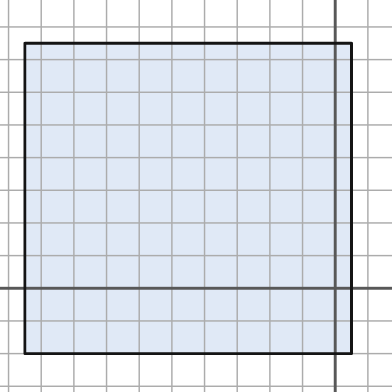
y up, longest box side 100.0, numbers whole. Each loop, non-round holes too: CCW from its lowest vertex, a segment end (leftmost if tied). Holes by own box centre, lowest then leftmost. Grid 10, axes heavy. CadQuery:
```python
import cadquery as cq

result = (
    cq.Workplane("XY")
    .moveTo(-95.0, -20.0)
    .lineTo(5.0, -20.0)
    .lineTo(5.0, 75.0)
    .lineTo(-95.0, 75.0)
    .close()
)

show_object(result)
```